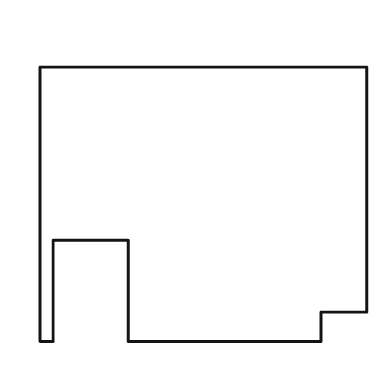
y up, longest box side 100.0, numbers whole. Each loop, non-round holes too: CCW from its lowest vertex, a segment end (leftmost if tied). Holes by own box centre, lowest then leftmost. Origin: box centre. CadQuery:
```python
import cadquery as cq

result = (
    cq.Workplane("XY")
    .moveTo(-50.0, -42.0)
    .lineTo(-46.0, -42.0)
    .lineTo(-46.0, -11.0)
    .lineTo(-23.0, -11.0)
    .lineTo(-23.0, -42.0)
    .lineTo(36.0, -42.0)
    .lineTo(36.0, -33.0)
    .lineTo(50.0, -33.0)
    .lineTo(50.0, 42.0)
    .lineTo(-50.0, 42.0)
    .close()
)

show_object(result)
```